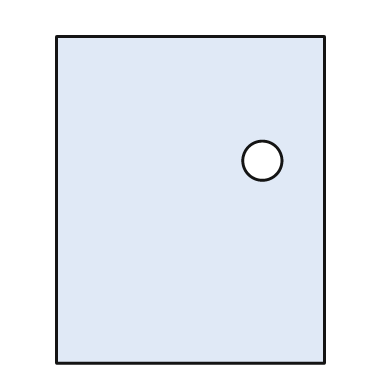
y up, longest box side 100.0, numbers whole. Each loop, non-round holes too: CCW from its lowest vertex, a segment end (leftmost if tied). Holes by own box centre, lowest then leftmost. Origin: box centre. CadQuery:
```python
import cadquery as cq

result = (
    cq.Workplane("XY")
    .moveTo(-41.0, -50.0)
    .lineTo(41.0, -50.0)
    .lineTo(41.0, 50.0)
    .lineTo(-41.0, 50.0)
    .close()
    .moveTo(22.0, 12.0)
    .circle(6.0)
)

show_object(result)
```